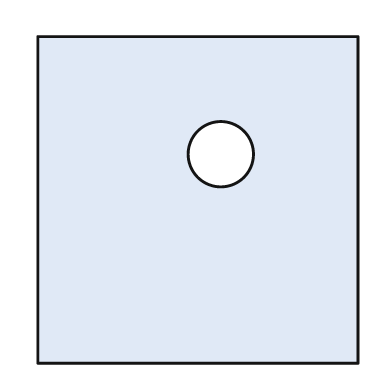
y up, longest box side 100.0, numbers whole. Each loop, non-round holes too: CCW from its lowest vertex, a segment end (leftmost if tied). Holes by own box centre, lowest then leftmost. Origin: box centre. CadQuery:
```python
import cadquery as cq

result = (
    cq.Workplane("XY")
    .moveTo(-49.0, -50.0)
    .lineTo(49.0, -50.0)
    .lineTo(49.0, 50.0)
    .lineTo(-49.0, 50.0)
    .close()
    .moveTo(7.0, 14.0)
    .circle(10.0)
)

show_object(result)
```